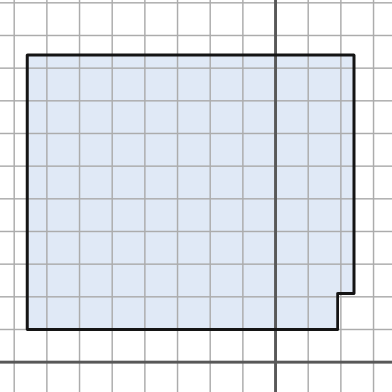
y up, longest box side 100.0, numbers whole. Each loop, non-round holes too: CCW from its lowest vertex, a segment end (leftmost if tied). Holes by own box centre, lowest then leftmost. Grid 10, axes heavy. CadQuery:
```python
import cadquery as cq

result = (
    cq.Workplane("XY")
    .moveTo(-76.0, 10.0)
    .lineTo(19.0, 10.0)
    .lineTo(19.0, 21.0)
    .lineTo(24.0, 21.0)
    .lineTo(24.0, 94.0)
    .lineTo(-76.0, 94.0)
    .close()
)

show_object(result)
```